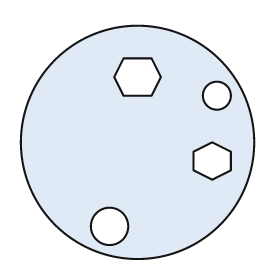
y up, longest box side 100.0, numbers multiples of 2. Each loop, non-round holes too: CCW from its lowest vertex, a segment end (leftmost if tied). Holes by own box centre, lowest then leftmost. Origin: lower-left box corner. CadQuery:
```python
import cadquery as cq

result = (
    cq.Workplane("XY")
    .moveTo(50.0, 50.0)
    .circle(50.0)
    .moveTo(38.0, 14.0)
    .circle(8.0)
    .moveTo(82.0, 34.0)
    .lineTo(90.0, 38.0)
    .lineTo(90.0, 46.0)
    .lineTo(82.0, 50.0)
    .lineTo(74.0, 46.0)
    .lineTo(74.0, 38.0)
    .close()
    .moveTo(84.0, 70.0)
    .circle(6.0)
    .moveTo(44.0, 70.0)
    .lineTo(56.0, 70.0)
    .lineTo(60.0, 78.0)
    .lineTo(56.0, 86.0)
    .lineTo(44.0, 86.0)
    .lineTo(40.0, 78.0)
    .close()
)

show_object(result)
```